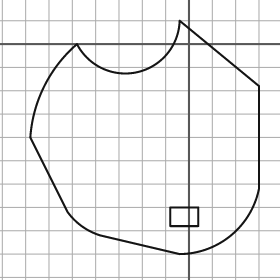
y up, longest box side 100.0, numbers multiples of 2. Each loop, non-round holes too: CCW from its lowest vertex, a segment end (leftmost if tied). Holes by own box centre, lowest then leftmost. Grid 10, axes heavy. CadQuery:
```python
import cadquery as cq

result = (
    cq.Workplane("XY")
    .moveTo(-4.0, -90.0)
    .threePointArc((18.0, -82.0), (30.0, -62.0))
    .lineTo(30.0, -18.0)
    .lineTo(-4.0, 10.0)
    .threePointArc((-22.0, -12.0), (-48.0, 0.0))
    .threePointArc((-62.0, -18.0), (-68.0, -40.0))
    .lineTo(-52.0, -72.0)
    .threePointArc((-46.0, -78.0), (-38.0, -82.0))
    .close()
    .moveTo(-8.0, -78.0)
    .lineTo(4.0, -78.0)
    .lineTo(4.0, -70.0)
    .lineTo(-8.0, -70.0)
    .close()
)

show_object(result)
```